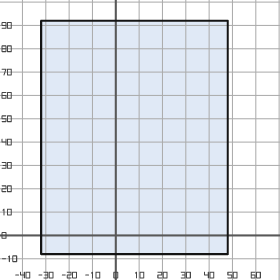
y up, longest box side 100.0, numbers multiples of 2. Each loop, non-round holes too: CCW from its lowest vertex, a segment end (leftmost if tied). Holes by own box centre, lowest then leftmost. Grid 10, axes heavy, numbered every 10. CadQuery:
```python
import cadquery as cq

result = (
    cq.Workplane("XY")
    .moveTo(-32.0, -8.0)
    .lineTo(48.0, -8.0)
    .lineTo(48.0, 92.0)
    .lineTo(-32.0, 92.0)
    .close()
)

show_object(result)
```